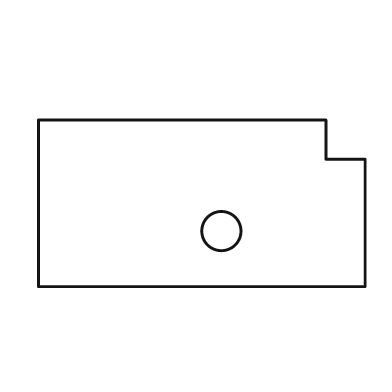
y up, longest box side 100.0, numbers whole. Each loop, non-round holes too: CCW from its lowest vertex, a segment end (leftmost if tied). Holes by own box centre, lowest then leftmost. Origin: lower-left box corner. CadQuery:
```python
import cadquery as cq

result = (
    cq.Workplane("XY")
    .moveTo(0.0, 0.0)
    .lineTo(100.0, 0.0)
    .lineTo(100.0, 39.0)
    .lineTo(88.0, 39.0)
    .lineTo(88.0, 51.0)
    .lineTo(0.0, 51.0)
    .close()
    .moveTo(56.0, 17.0)
    .circle(6.0)
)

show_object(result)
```